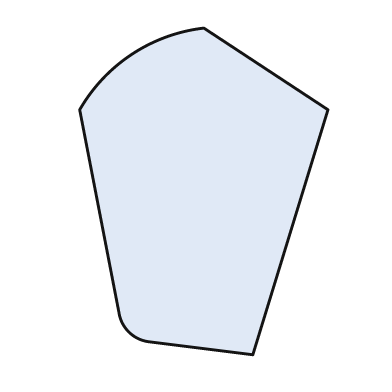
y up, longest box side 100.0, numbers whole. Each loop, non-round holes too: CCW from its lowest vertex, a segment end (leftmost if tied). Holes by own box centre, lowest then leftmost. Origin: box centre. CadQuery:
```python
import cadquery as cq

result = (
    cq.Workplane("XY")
    .moveTo(15.0, -50.0)
    .lineTo(38.0, 25.0)
    .lineTo(0.0, 50.0)
    .threePointArc((-22.0, 42.0), (-38.0, 25.0))
    .lineTo(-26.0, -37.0)
    .threePointArc((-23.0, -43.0), (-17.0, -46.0))
    .close()
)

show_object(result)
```